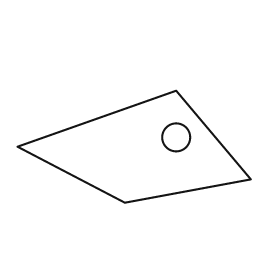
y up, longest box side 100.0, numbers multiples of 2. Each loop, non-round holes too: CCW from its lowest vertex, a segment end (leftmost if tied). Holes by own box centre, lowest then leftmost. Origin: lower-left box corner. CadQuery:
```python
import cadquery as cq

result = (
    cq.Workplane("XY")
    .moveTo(46.0, 0.0)
    .lineTo(100.0, 10.0)
    .lineTo(68.0, 48.0)
    .lineTo(0.0, 24.0)
    .close()
    .moveTo(68.0, 28.0)
    .circle(6.0)
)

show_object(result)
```